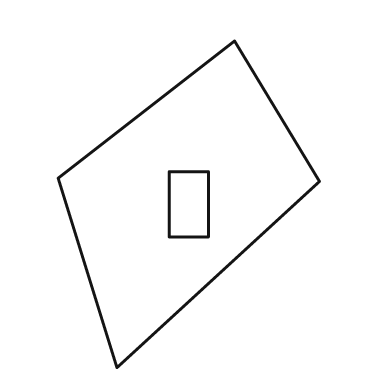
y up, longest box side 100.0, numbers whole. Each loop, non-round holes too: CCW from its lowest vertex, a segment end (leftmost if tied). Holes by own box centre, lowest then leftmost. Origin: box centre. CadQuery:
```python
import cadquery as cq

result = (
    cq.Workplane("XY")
    .moveTo(-22.0, -50.0)
    .lineTo(40.0, 7.0)
    .lineTo(14.0, 50.0)
    .lineTo(-40.0, 8.0)
    .close()
    .moveTo(-6.0, -10.0)
    .lineTo(6.0, -10.0)
    .lineTo(6.0, 10.0)
    .lineTo(-6.0, 10.0)
    .close()
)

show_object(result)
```